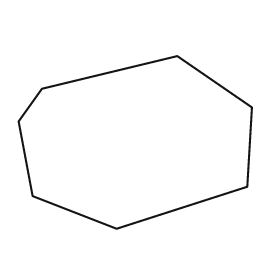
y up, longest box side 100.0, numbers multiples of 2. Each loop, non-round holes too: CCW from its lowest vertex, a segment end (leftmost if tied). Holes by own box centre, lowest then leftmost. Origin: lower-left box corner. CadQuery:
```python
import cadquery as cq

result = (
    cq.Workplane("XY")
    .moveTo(42.0, 0.0)
    .lineTo(98.0, 18.0)
    .lineTo(100.0, 52.0)
    .lineTo(68.0, 74.0)
    .lineTo(10.0, 60.0)
    .lineTo(0.0, 46.0)
    .lineTo(6.0, 14.0)
    .close()
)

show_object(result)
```